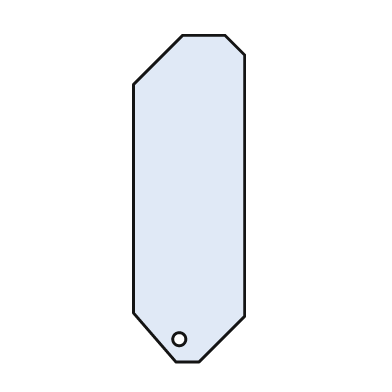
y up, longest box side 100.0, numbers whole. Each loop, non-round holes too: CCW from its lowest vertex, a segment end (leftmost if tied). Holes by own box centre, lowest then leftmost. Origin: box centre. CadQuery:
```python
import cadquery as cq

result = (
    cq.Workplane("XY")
    .moveTo(-4.0, -50.0)
    .lineTo(3.0, -50.0)
    .lineTo(17.0, -36.0)
    .lineTo(17.0, 44.0)
    .lineTo(11.0, 50.0)
    .lineTo(-2.0, 50.0)
    .lineTo(-17.0, 35.0)
    .lineTo(-17.0, -35.0)
    .close()
    .moveTo(-3.0, -43.0)
    .circle(2.0)
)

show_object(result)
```